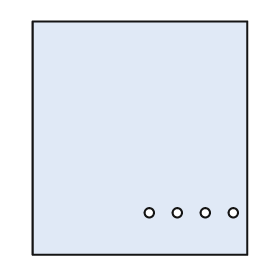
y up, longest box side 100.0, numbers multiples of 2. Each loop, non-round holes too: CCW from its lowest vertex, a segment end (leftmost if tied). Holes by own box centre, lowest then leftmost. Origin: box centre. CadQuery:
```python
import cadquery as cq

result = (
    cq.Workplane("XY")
    .moveTo(-46.0, -50.0)
    .lineTo(46.0, -50.0)
    .lineTo(46.0, 50.0)
    .lineTo(-46.0, 50.0)
    .close()
    .moveTo(4.0, -32.0)
    .circle(2.0)
    .moveTo(16.0, -32.0)
    .circle(2.0)
    .moveTo(28.0, -32.0)
    .circle(2.0)
    .moveTo(40.0, -32.0)
    .circle(2.0)
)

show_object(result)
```